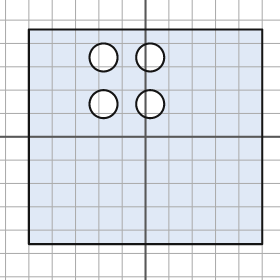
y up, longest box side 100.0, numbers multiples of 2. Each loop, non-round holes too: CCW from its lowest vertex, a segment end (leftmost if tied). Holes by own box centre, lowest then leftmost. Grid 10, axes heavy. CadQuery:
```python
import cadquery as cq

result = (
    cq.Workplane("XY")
    .moveTo(-50.0, -46.0)
    .lineTo(50.0, -46.0)
    .lineTo(50.0, 46.0)
    .lineTo(-50.0, 46.0)
    .close()
    .moveTo(-18.0, 14.0)
    .circle(6.0)
    .moveTo(2.0, 14.0)
    .circle(6.0)
    .moveTo(-18.0, 34.0)
    .circle(6.0)
    .moveTo(2.0, 34.0)
    .circle(6.0)
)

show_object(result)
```